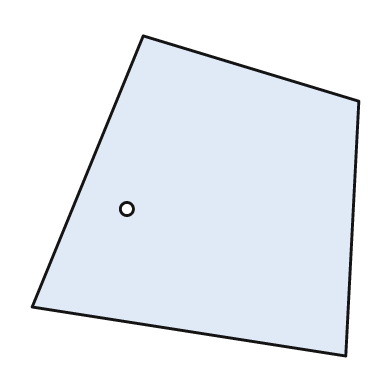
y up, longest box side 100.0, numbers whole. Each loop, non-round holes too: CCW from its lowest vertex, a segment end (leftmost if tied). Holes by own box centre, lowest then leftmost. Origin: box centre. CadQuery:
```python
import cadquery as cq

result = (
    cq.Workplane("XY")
    .moveTo(46.0, -49.0)
    .lineTo(50.0, 29.0)
    .lineTo(-16.0, 49.0)
    .lineTo(-50.0, -34.0)
    .close()
    .moveTo(-21.0, -4.0)
    .circle(2.0)
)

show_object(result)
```